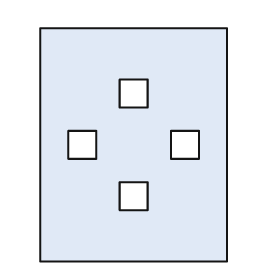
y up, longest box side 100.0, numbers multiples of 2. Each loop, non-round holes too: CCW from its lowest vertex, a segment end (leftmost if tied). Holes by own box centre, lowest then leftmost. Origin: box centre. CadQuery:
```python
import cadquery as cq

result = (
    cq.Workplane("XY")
    .moveTo(-40.0, -50.0)
    .lineTo(40.0, -50.0)
    .lineTo(40.0, 50.0)
    .lineTo(-40.0, 50.0)
    .close()
    .moveTo(-6.0, -28.0)
    .lineTo(6.0, -28.0)
    .lineTo(6.0, -16.0)
    .lineTo(-6.0, -16.0)
    .close()
    .moveTo(-28.0, -6.0)
    .lineTo(-16.0, -6.0)
    .lineTo(-16.0, 6.0)
    .lineTo(-28.0, 6.0)
    .close()
    .moveTo(16.0, -6.0)
    .lineTo(28.0, -6.0)
    .lineTo(28.0, 6.0)
    .lineTo(16.0, 6.0)
    .close()
    .moveTo(-6.0, 16.0)
    .lineTo(6.0, 16.0)
    .lineTo(6.0, 28.0)
    .lineTo(-6.0, 28.0)
    .close()
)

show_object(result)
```